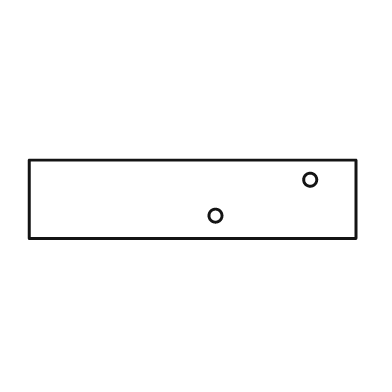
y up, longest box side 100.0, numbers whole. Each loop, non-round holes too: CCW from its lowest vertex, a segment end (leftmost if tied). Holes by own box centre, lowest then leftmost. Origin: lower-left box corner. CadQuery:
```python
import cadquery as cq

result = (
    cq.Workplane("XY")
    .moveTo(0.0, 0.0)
    .lineTo(100.0, 0.0)
    .lineTo(100.0, 24.0)
    .lineTo(0.0, 24.0)
    .close()
    .moveTo(57.0, 7.0)
    .circle(2.0)
    .moveTo(86.0, 18.0)
    .circle(2.0)
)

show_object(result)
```